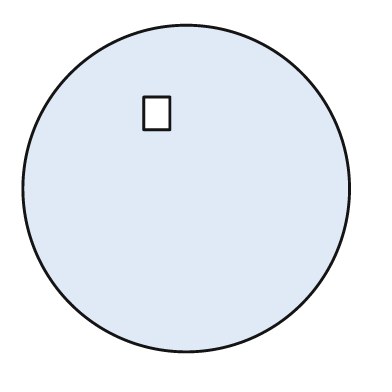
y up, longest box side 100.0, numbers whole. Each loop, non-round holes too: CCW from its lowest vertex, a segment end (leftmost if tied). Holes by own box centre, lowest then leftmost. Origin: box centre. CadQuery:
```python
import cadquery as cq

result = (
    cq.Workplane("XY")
    .moveTo(0.0, 0.0)
    .circle(50.0)
    .moveTo(-13.0, 18.0)
    .lineTo(-5.0, 18.0)
    .lineTo(-5.0, 28.0)
    .lineTo(-13.0, 28.0)
    .close()
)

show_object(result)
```